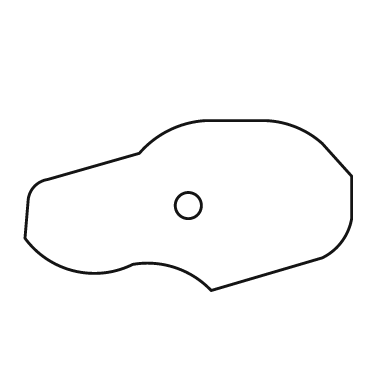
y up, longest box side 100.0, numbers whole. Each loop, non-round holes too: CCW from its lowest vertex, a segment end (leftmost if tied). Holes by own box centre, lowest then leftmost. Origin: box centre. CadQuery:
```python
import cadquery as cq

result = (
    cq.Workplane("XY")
    .moveTo(7.0, -26.0)
    .lineTo(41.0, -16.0)
    .threePointArc((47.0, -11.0), (50.0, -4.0))
    .lineTo(50.0, 9.0)
    .lineTo(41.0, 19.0)
    .threePointArc((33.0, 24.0), (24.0, 26.0))
    .lineTo(5.0, 26.0)
    .threePointArc((-6.0, 23.0), (-15.0, 16.0))
    .lineTo(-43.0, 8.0)
    .threePointArc((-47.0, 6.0), (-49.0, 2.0))
    .lineTo(-50.0, -10.0)
    .threePointArc((-35.0, -20.0), (-17.0, -18.0))
    .threePointArc((-4.0, -19.0), (7.0, -26.0))
    .close()
    .moveTo(0.0, 0.0)
    .circle(4.0)
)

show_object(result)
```